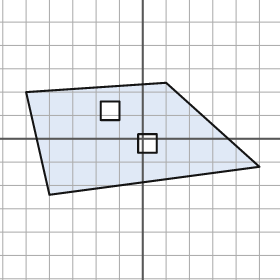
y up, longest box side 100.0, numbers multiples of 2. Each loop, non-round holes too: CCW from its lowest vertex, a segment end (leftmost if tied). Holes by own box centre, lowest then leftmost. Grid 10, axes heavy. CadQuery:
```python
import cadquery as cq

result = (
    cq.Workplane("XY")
    .moveTo(-40.0, -24.0)
    .lineTo(50.0, -12.0)
    .lineTo(10.0, 24.0)
    .lineTo(-50.0, 20.0)
    .close()
    .moveTo(-2.0, -6.0)
    .lineTo(6.0, -6.0)
    .lineTo(6.0, 2.0)
    .lineTo(-2.0, 2.0)
    .close()
    .moveTo(-18.0, 8.0)
    .lineTo(-10.0, 8.0)
    .lineTo(-10.0, 16.0)
    .lineTo(-18.0, 16.0)
    .close()
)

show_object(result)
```